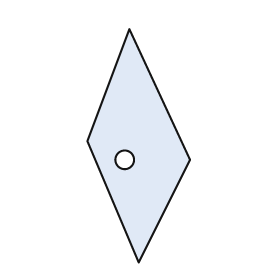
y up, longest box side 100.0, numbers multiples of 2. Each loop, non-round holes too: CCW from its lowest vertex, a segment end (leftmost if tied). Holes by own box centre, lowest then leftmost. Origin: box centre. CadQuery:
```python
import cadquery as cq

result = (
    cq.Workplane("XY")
    .moveTo(0.0, -50.0)
    .lineTo(22.0, -6.0)
    .lineTo(-4.0, 50.0)
    .lineTo(-22.0, 2.0)
    .close()
    .moveTo(-6.0, -6.0)
    .circle(4.0)
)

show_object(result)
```